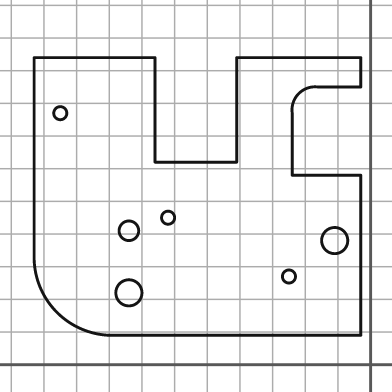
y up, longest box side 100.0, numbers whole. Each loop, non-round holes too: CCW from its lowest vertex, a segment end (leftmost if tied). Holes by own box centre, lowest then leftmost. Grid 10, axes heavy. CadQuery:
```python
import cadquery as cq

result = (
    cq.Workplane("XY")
    .moveTo(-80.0, 9.0)
    .lineTo(-3.0, 9.0)
    .lineTo(-3.0, 58.0)
    .lineTo(-24.0, 58.0)
    .lineTo(-24.0, 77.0)
    .threePointArc((-22.0, 83.0), (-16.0, 85.0))
    .lineTo(-3.0, 85.0)
    .lineTo(-3.0, 94.0)
    .lineTo(-41.0, 94.0)
    .lineTo(-41.0, 62.0)
    .lineTo(-66.0, 62.0)
    .lineTo(-66.0, 94.0)
    .lineTo(-103.0, 94.0)
    .lineTo(-103.0, 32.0)
    .threePointArc((-96.0, 16.0), (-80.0, 9.0))
    .close()
    .moveTo(-74.0, 22.0)
    .circle(4.0)
    .moveTo(-25.0, 27.0)
    .circle(2.0)
    .moveTo(-11.0, 38.0)
    .circle(4.0)
    .moveTo(-74.0, 41.0)
    .circle(3.0)
    .moveTo(-62.0, 45.0)
    .circle(2.0)
    .moveTo(-95.0, 77.0)
    .circle(2.0)
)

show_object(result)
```